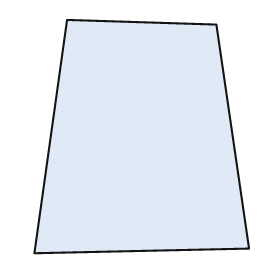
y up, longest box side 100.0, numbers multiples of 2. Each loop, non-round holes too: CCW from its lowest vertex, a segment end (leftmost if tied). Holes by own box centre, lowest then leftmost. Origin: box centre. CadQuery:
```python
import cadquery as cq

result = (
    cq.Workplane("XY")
    .moveTo(-46.0, -50.0)
    .lineTo(46.0, -48.0)
    .lineTo(32.0, 48.0)
    .lineTo(-32.0, 50.0)
    .close()
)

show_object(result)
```